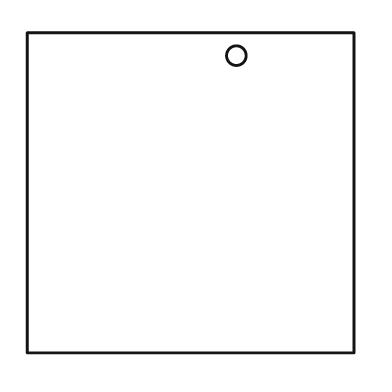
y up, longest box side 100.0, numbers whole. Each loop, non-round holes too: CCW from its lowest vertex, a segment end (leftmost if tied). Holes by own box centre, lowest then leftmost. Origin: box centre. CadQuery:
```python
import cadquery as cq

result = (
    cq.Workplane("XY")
    .moveTo(-50.0, -49.0)
    .lineTo(50.0, -49.0)
    .lineTo(50.0, 49.0)
    .lineTo(-50.0, 49.0)
    .close()
    .moveTo(14.0, 42.0)
    .circle(3.0)
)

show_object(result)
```